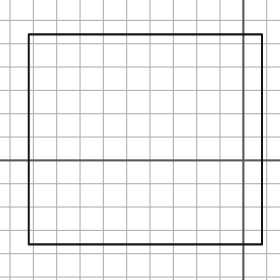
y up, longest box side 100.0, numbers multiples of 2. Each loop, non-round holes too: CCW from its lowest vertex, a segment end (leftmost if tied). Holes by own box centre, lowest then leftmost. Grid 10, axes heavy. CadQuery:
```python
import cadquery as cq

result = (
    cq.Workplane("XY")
    .moveTo(-92.0, -36.0)
    .lineTo(8.0, -36.0)
    .lineTo(8.0, 54.0)
    .lineTo(-92.0, 54.0)
    .close()
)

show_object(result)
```